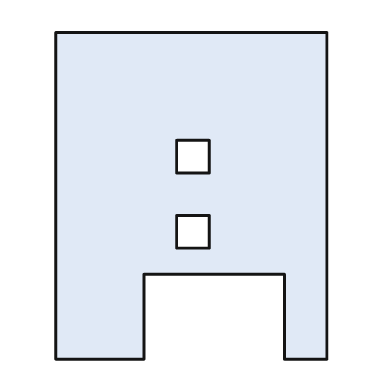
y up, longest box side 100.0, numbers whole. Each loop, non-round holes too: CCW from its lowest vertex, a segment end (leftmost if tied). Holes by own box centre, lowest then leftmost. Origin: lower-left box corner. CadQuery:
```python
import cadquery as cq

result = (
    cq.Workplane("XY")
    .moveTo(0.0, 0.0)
    .lineTo(27.0, 0.0)
    .lineTo(27.0, 26.0)
    .lineTo(70.0, 26.0)
    .lineTo(70.0, 0.0)
    .lineTo(83.0, 0.0)
    .lineTo(83.0, 100.0)
    .lineTo(0.0, 100.0)
    .close()
    .moveTo(37.0, 34.0)
    .lineTo(47.0, 34.0)
    .lineTo(47.0, 44.0)
    .lineTo(37.0, 44.0)
    .close()
    .moveTo(37.0, 57.0)
    .lineTo(47.0, 57.0)
    .lineTo(47.0, 67.0)
    .lineTo(37.0, 67.0)
    .close()
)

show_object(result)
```